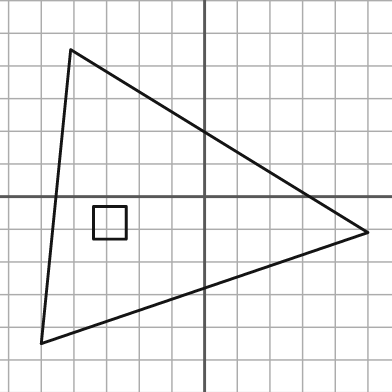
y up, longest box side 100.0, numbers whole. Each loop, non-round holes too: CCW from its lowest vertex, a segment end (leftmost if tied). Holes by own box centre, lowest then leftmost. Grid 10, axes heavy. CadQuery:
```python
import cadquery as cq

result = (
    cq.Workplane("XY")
    .moveTo(-50.0, -45.0)
    .lineTo(50.0, -11.0)
    .lineTo(-41.0, 45.0)
    .close()
    .moveTo(-34.0, -13.0)
    .lineTo(-24.0, -13.0)
    .lineTo(-24.0, -3.0)
    .lineTo(-34.0, -3.0)
    .close()
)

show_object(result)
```